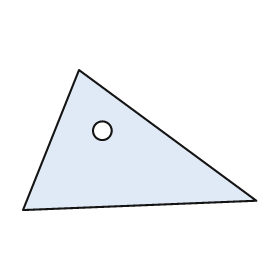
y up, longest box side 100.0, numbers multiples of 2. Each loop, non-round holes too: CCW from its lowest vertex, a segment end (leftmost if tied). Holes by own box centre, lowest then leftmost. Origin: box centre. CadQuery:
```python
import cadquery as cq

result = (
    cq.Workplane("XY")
    .moveTo(-50.0, -30.0)
    .lineTo(50.0, -26.0)
    .lineTo(-26.0, 30.0)
    .close()
    .moveTo(-16.0, 4.0)
    .circle(4.0)
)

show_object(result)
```